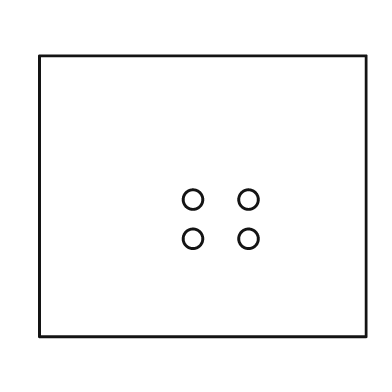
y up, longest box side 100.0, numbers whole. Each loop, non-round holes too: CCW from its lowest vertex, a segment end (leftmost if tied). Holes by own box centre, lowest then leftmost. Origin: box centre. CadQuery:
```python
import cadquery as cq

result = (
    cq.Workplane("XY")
    .moveTo(-50.0, -43.0)
    .lineTo(50.0, -43.0)
    .lineTo(50.0, 43.0)
    .lineTo(-50.0, 43.0)
    .close()
    .moveTo(-3.0, -13.0)
    .circle(3.0)
    .moveTo(14.0, -13.0)
    .circle(3.0)
    .moveTo(-3.0, -1.0)
    .circle(3.0)
    .moveTo(14.0, -1.0)
    .circle(3.0)
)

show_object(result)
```